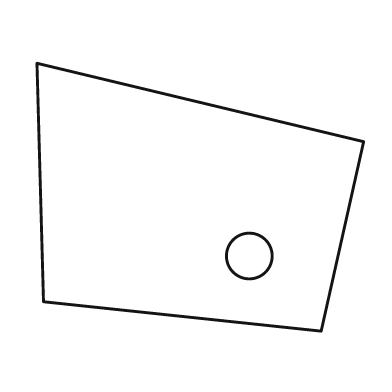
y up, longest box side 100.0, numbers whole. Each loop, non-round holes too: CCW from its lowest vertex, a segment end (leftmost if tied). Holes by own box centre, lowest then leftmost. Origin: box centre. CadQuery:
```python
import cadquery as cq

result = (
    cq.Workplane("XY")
    .moveTo(37.0, -41.0)
    .lineTo(50.0, 17.0)
    .lineTo(-50.0, 41.0)
    .lineTo(-48.0, -32.0)
    .close()
    .moveTo(15.0, -18.0)
    .circle(7.0)
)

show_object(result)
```